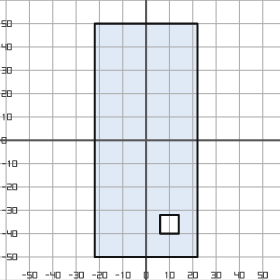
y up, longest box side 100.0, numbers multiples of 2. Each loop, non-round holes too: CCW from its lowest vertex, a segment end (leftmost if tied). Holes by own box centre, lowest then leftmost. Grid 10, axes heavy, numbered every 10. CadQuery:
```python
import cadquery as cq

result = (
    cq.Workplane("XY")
    .moveTo(-22.0, -50.0)
    .lineTo(22.0, -50.0)
    .lineTo(22.0, 50.0)
    .lineTo(-22.0, 50.0)
    .close()
    .moveTo(6.0, -40.0)
    .lineTo(14.0, -40.0)
    .lineTo(14.0, -32.0)
    .lineTo(6.0, -32.0)
    .close()
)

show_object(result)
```